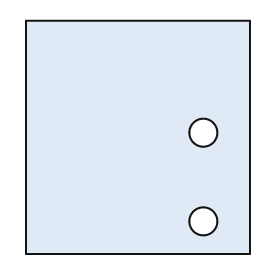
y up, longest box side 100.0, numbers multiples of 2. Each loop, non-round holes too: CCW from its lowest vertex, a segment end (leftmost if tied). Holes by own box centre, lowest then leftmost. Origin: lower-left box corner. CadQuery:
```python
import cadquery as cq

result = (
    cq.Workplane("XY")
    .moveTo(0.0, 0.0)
    .lineTo(96.0, 0.0)
    .lineTo(96.0, 100.0)
    .lineTo(0.0, 100.0)
    .close()
    .moveTo(76.0, 14.0)
    .circle(6.0)
    .moveTo(76.0, 52.0)
    .circle(6.0)
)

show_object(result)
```